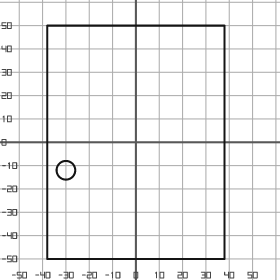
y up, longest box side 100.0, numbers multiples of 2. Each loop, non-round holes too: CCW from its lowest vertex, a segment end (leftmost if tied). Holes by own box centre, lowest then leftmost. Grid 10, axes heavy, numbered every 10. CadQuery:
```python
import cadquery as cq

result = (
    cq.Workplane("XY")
    .moveTo(-38.0, -50.0)
    .lineTo(38.0, -50.0)
    .lineTo(38.0, 50.0)
    .lineTo(-38.0, 50.0)
    .close()
    .moveTo(-30.0, -12.0)
    .circle(4.0)
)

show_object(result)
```